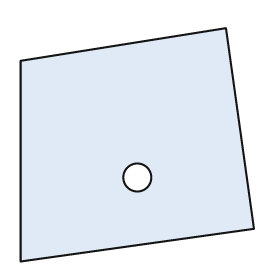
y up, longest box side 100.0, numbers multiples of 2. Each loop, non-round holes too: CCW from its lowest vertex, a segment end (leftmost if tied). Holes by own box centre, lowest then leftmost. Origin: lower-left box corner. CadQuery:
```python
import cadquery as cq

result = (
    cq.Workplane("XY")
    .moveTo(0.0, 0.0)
    .lineTo(100.0, 14.0)
    .lineTo(88.0, 100.0)
    .lineTo(0.0, 86.0)
    .close()
    .moveTo(50.0, 36.0)
    .circle(6.0)
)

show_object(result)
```